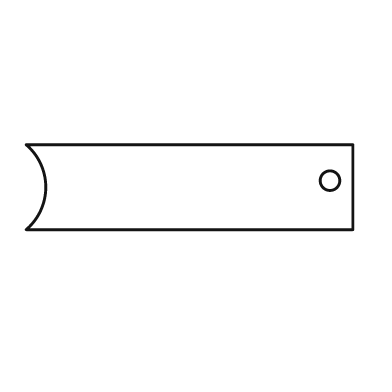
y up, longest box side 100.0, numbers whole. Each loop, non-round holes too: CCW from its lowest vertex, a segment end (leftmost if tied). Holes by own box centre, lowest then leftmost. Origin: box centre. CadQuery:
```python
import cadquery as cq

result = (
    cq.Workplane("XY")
    .moveTo(-50.0, -13.0)
    .lineTo(50.0, -13.0)
    .lineTo(50.0, 13.0)
    .lineTo(-50.0, 13.0)
    .threePointArc((-44.0, 0.0), (-50.0, -13.0))
    .close()
    .moveTo(43.0, 2.0)
    .circle(3.0)
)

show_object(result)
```